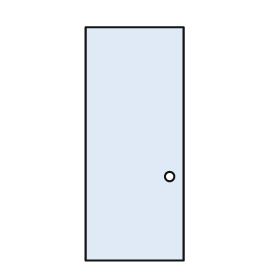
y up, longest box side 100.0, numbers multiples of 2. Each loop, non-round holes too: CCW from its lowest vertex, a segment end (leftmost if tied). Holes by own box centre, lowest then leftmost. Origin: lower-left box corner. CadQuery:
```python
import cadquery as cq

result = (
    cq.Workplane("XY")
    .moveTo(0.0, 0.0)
    .lineTo(42.0, 0.0)
    .lineTo(42.0, 100.0)
    .lineTo(0.0, 100.0)
    .close()
    .moveTo(36.0, 36.0)
    .circle(2.0)
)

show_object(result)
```